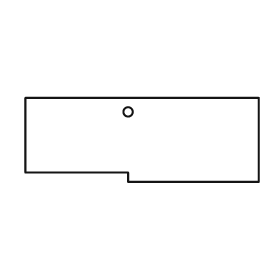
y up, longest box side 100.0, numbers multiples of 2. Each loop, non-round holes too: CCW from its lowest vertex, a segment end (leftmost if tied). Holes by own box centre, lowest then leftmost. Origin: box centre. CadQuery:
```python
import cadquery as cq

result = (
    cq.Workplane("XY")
    .moveTo(-6.0, -18.0)
    .lineTo(50.0, -18.0)
    .lineTo(50.0, 18.0)
    .lineTo(-50.0, 18.0)
    .lineTo(-50.0, -14.0)
    .lineTo(-6.0, -14.0)
    .close()
    .moveTo(-6.0, 12.0)
    .circle(2.0)
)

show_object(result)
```